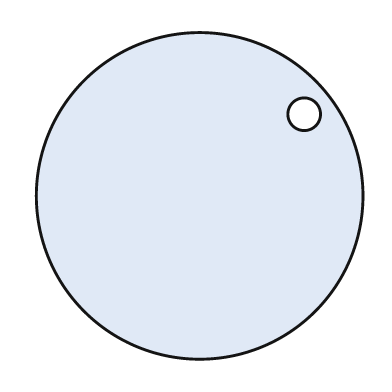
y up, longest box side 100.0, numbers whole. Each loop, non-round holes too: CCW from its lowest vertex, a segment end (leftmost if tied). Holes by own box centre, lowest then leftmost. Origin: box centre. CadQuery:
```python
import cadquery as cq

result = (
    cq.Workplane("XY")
    .moveTo(0.0, 0.0)
    .circle(50.0)
    .moveTo(32.0, 25.0)
    .circle(5.0)
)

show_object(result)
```